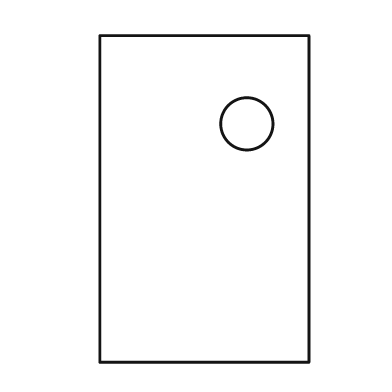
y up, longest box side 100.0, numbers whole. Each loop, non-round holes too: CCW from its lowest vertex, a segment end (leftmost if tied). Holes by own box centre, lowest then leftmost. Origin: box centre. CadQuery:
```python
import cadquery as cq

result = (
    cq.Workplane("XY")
    .moveTo(-32.0, -50.0)
    .lineTo(32.0, -50.0)
    .lineTo(32.0, 50.0)
    .lineTo(-32.0, 50.0)
    .close()
    .moveTo(13.0, 23.0)
    .circle(8.0)
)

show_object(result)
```